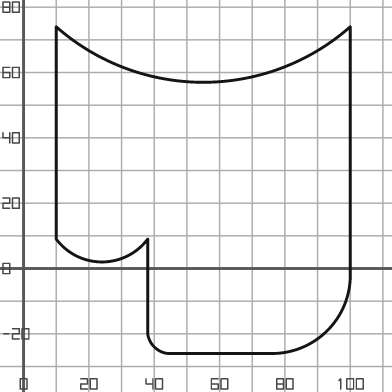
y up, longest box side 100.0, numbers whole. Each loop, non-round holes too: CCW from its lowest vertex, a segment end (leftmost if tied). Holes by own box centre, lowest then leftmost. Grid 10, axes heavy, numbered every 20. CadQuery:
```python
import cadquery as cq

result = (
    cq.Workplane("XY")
    .moveTo(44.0, -26.0)
    .lineTo(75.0, -26.0)
    .threePointArc((93.0, -19.0), (100.0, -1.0))
    .lineTo(100.0, 74.0)
    .threePointArc((55.0, 57.0), (10.0, 74.0))
    .lineTo(10.0, 9.0)
    .threePointArc((24.0, 2.0), (38.0, 9.0))
    .lineTo(38.0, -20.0)
    .threePointArc((40.0, -24.0), (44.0, -26.0))
    .close()
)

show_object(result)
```